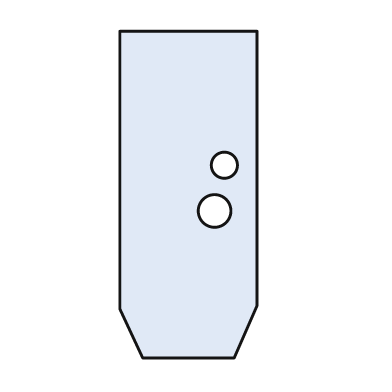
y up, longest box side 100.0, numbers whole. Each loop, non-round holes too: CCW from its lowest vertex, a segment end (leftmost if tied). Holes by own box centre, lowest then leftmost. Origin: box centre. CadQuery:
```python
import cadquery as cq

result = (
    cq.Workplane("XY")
    .moveTo(-14.0, -50.0)
    .lineTo(14.0, -50.0)
    .lineTo(21.0, -34.0)
    .lineTo(21.0, 50.0)
    .lineTo(-21.0, 50.0)
    .lineTo(-21.0, -35.0)
    .close()
    .moveTo(8.0, -5.0)
    .circle(5.0)
    .moveTo(11.0, 9.0)
    .circle(4.0)
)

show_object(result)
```